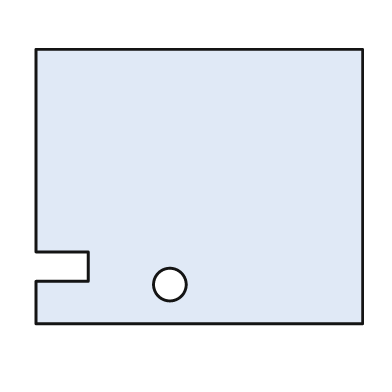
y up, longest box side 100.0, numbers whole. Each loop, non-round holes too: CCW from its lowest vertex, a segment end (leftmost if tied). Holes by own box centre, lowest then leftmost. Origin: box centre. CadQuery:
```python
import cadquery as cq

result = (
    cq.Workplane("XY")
    .moveTo(-50.0, -42.0)
    .lineTo(50.0, -42.0)
    .lineTo(50.0, 42.0)
    .lineTo(-50.0, 42.0)
    .lineTo(-50.0, -20.0)
    .lineTo(-34.0, -20.0)
    .lineTo(-34.0, -29.0)
    .lineTo(-50.0, -29.0)
    .close()
    .moveTo(-9.0, -30.0)
    .circle(5.0)
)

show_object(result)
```